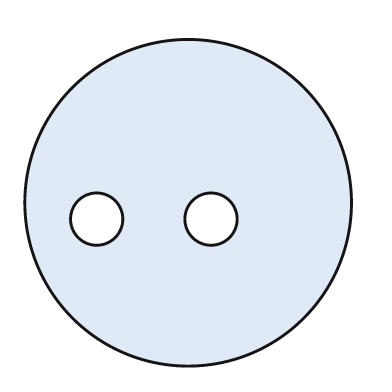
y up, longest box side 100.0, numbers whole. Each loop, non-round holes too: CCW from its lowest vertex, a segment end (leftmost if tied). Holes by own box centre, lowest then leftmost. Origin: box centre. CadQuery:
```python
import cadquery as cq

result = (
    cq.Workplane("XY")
    .moveTo(0.0, 0.0)
    .circle(50.0)
    .moveTo(-28.0, -5.0)
    .circle(8.0)
    .moveTo(7.0, -5.0)
    .circle(8.0)
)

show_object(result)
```